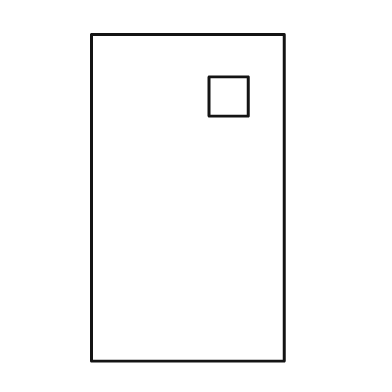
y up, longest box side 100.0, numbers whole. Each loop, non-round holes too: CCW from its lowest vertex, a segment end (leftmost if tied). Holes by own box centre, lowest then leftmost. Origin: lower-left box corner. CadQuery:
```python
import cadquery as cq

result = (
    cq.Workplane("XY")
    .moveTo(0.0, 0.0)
    .lineTo(59.0, 0.0)
    .lineTo(59.0, 100.0)
    .lineTo(0.0, 100.0)
    .close()
    .moveTo(36.0, 75.0)
    .lineTo(48.0, 75.0)
    .lineTo(48.0, 87.0)
    .lineTo(36.0, 87.0)
    .close()
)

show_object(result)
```